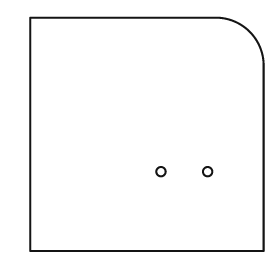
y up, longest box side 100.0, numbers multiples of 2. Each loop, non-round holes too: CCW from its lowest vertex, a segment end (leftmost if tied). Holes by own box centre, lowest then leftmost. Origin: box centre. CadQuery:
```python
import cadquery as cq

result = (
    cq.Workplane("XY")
    .moveTo(-50.0, -50.0)
    .lineTo(50.0, -50.0)
    .lineTo(50.0, 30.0)
    .threePointArc((44.0, 44.0), (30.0, 50.0))
    .lineTo(-50.0, 50.0)
    .close()
    .moveTo(6.0, -16.0)
    .circle(2.0)
    .moveTo(26.0, -16.0)
    .circle(2.0)
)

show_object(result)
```